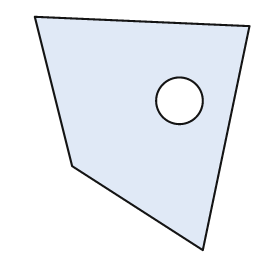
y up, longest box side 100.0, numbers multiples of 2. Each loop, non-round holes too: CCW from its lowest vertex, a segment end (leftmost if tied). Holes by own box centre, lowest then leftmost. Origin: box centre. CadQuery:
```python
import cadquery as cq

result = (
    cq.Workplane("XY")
    .moveTo(26.0, -50.0)
    .lineTo(46.0, 46.0)
    .lineTo(-46.0, 50.0)
    .lineTo(-30.0, -14.0)
    .close()
    .moveTo(16.0, 14.0)
    .circle(10.0)
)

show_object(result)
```